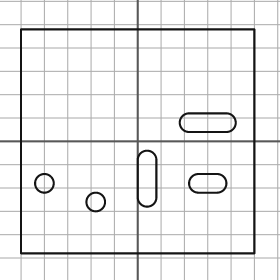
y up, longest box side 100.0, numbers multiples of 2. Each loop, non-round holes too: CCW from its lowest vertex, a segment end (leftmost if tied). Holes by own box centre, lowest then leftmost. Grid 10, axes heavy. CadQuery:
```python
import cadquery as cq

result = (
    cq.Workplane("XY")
    .moveTo(-50.0, -48.0)
    .lineTo(50.0, -48.0)
    .lineTo(50.0, 48.0)
    .lineTo(-50.0, 48.0)
    .close()
    .moveTo(-18.0, -26.0)
    .circle(4.0)
    .moveTo(-40.0, -18.0)
    .circle(4.0)
    .moveTo(26.0, -22.0)
    .lineTo(34.0, -22.0)
    .threePointArc((38.0, -18.0), (34.0, -14.0))
    .lineTo(26.0, -14.0)
    .threePointArc((22.0, -18.0), (26.0, -22.0))
    .close()
    .moveTo(0.0, -24.0)
    .threePointArc((4.0, -28.0), (8.0, -24.0))
    .lineTo(8.0, -8.0)
    .threePointArc((4.0, -4.0), (0.0, -8.0))
    .close()
    .moveTo(22.0, 4.0)
    .lineTo(38.0, 4.0)
    .threePointArc((42.0, 8.0), (38.0, 12.0))
    .lineTo(22.0, 12.0)
    .threePointArc((18.0, 8.0), (22.0, 4.0))
    .close()
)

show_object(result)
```